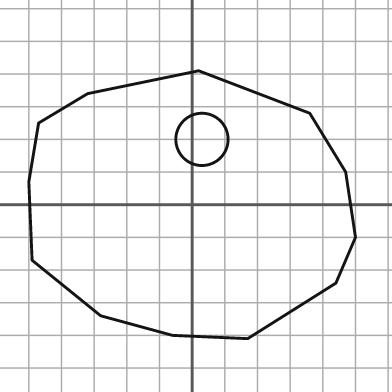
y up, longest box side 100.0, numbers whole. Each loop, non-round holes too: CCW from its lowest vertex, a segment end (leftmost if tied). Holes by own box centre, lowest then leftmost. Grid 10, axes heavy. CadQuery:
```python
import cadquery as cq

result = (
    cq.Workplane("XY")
    .moveTo(17.0, -41.0)
    .lineTo(44.0, -24.0)
    .lineTo(50.0, -10.0)
    .lineTo(47.0, 10.0)
    .lineTo(36.0, 28.0)
    .lineTo(2.0, 41.0)
    .lineTo(-32.0, 34.0)
    .lineTo(-47.0, 25.0)
    .lineTo(-50.0, 7.0)
    .lineTo(-49.0, -17.0)
    .lineTo(-28.0, -34.0)
    .lineTo(-6.0, -40.0)
    .close()
    .moveTo(3.0, 20.0)
    .circle(8.0)
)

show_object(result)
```